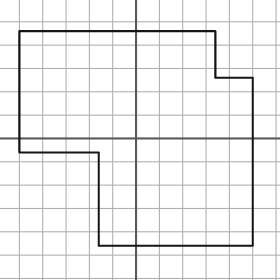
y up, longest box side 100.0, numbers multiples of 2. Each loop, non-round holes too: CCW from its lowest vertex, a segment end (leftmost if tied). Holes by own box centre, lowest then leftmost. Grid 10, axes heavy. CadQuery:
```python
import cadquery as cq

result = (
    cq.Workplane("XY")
    .moveTo(-16.0, -46.0)
    .lineTo(50.0, -46.0)
    .lineTo(50.0, 26.0)
    .lineTo(34.0, 26.0)
    .lineTo(34.0, 46.0)
    .lineTo(-50.0, 46.0)
    .lineTo(-50.0, -6.0)
    .lineTo(-16.0, -6.0)
    .close()
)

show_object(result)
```